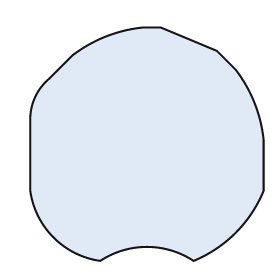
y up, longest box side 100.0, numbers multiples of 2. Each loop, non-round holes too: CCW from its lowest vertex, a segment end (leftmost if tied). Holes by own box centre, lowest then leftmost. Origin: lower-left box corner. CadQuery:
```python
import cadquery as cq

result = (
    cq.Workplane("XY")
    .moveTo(30.0, 0.0)
    .threePointArc((50.0, 6.0), (70.0, 0.0))
    .threePointArc((88.0, 12.0), (100.0, 30.0))
    .lineTo(100.0, 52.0)
    .threePointArc((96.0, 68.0), (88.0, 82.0))
    .lineTo(80.0, 90.0)
    .lineTo(56.0, 100.0)
    .lineTo(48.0, 100.0)
    .threePointArc((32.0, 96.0), (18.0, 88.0))
    .lineTo(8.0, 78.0)
    .threePointArc((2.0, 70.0), (0.0, 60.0))
    .lineTo(0.0, 30.0)
    .threePointArc((10.0, 10.0), (30.0, 0.0))
    .close()
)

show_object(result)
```